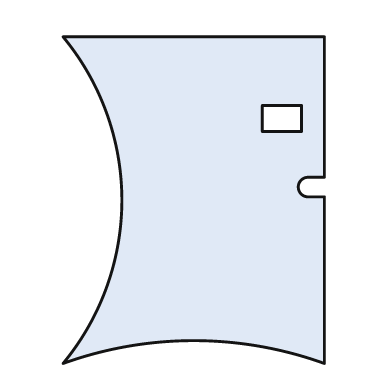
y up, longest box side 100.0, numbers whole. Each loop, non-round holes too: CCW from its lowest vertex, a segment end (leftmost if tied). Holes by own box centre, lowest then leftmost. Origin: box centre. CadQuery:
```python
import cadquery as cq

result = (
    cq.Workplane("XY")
    .moveTo(-40.0, -50.0)
    .threePointArc((0.0, -43.0), (40.0, -50.0))
    .lineTo(40.0, 1.0)
    .lineTo(35.0, 1.0)
    .threePointArc((32.0, 4.0), (35.0, 7.0))
    .lineTo(40.0, 7.0)
    .lineTo(40.0, 50.0)
    .lineTo(-40.0, 50.0)
    .threePointArc((-22.0, 0.0), (-40.0, -50.0))
    .close()
    .moveTo(21.0, 21.0)
    .lineTo(33.0, 21.0)
    .lineTo(33.0, 29.0)
    .lineTo(21.0, 29.0)
    .close()
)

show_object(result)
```